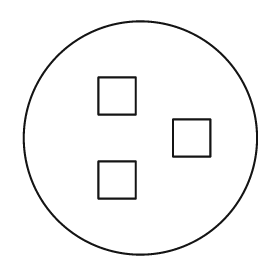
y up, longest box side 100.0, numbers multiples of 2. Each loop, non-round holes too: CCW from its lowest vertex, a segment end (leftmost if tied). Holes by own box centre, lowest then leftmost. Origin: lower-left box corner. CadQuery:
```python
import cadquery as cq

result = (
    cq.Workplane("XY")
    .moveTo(50.0, 50.0)
    .circle(50.0)
    .moveTo(32.0, 24.0)
    .lineTo(48.0, 24.0)
    .lineTo(48.0, 40.0)
    .lineTo(32.0, 40.0)
    .close()
    .moveTo(64.0, 42.0)
    .lineTo(80.0, 42.0)
    .lineTo(80.0, 58.0)
    .lineTo(64.0, 58.0)
    .close()
    .moveTo(32.0, 60.0)
    .lineTo(48.0, 60.0)
    .lineTo(48.0, 76.0)
    .lineTo(32.0, 76.0)
    .close()
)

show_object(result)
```